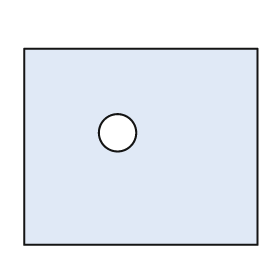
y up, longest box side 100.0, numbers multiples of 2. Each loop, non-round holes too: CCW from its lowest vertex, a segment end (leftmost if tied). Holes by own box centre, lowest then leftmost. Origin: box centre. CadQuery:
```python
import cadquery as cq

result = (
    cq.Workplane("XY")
    .moveTo(-50.0, -42.0)
    .lineTo(50.0, -42.0)
    .lineTo(50.0, 42.0)
    .lineTo(-50.0, 42.0)
    .close()
    .moveTo(-10.0, 6.0)
    .circle(8.0)
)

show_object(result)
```